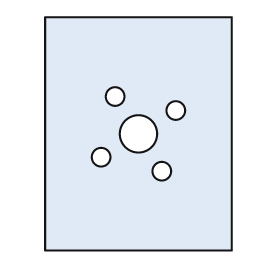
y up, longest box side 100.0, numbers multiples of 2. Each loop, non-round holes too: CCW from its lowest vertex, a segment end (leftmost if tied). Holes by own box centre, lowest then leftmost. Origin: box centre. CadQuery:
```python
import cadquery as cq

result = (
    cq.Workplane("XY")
    .moveTo(-40.0, -50.0)
    .lineTo(40.0, -50.0)
    .lineTo(40.0, 50.0)
    .lineTo(-40.0, 50.0)
    .close()
    .moveTo(10.0, -16.0)
    .circle(4.0)
    .moveTo(-16.0, -10.0)
    .circle(4.0)
    .moveTo(0.0, 0.0)
    .circle(8.0)
    .moveTo(16.0, 10.0)
    .circle(4.0)
    .moveTo(-10.0, 16.0)
    .circle(4.0)
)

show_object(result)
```